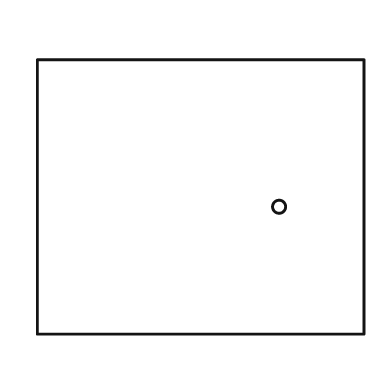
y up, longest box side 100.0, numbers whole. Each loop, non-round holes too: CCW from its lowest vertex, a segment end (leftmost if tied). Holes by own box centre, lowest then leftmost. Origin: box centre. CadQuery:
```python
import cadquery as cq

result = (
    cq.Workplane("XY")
    .moveTo(-50.0, -42.0)
    .lineTo(50.0, -42.0)
    .lineTo(50.0, 42.0)
    .lineTo(-50.0, 42.0)
    .close()
    .moveTo(24.0, -3.0)
    .circle(2.0)
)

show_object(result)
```